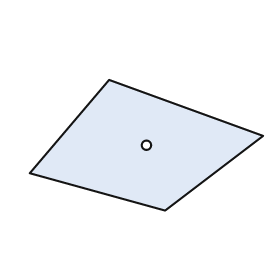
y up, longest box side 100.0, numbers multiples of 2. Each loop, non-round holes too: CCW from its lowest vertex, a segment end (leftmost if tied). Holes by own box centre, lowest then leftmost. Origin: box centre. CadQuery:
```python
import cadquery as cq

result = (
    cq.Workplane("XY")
    .moveTo(8.0, -28.0)
    .lineTo(50.0, 4.0)
    .lineTo(-16.0, 28.0)
    .lineTo(-50.0, -12.0)
    .close()
    .moveTo(0.0, 0.0)
    .circle(2.0)
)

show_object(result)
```